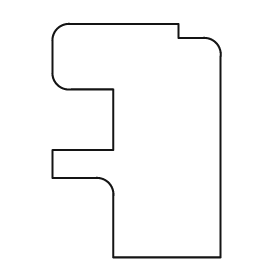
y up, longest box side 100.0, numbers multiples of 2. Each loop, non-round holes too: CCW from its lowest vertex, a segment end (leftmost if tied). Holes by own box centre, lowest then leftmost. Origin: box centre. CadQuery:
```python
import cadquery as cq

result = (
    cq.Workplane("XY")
    .moveTo(-10.0, -50.0)
    .lineTo(36.0, -50.0)
    .lineTo(36.0, 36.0)
    .threePointArc((34.0, 42.0), (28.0, 44.0))
    .lineTo(18.0, 44.0)
    .lineTo(18.0, 50.0)
    .lineTo(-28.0, 50.0)
    .threePointArc((-34.0, 48.0), (-36.0, 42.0))
    .lineTo(-36.0, 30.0)
    .threePointArc((-34.0, 24.0), (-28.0, 22.0))
    .lineTo(-10.0, 22.0)
    .lineTo(-10.0, -4.0)
    .lineTo(-36.0, -4.0)
    .lineTo(-36.0, -16.0)
    .lineTo(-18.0, -16.0)
    .threePointArc((-12.0, -18.0), (-10.0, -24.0))
    .close()
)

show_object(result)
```